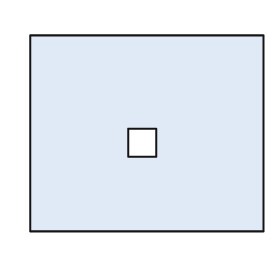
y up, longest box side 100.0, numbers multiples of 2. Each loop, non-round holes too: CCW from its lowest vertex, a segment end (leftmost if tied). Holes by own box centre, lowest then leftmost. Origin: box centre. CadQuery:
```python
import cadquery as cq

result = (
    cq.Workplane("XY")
    .moveTo(-50.0, -42.0)
    .lineTo(50.0, -42.0)
    .lineTo(50.0, 42.0)
    .lineTo(-50.0, 42.0)
    .close()
    .moveTo(-8.0, -10.0)
    .lineTo(4.0, -10.0)
    .lineTo(4.0, 2.0)
    .lineTo(-8.0, 2.0)
    .close()
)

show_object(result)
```